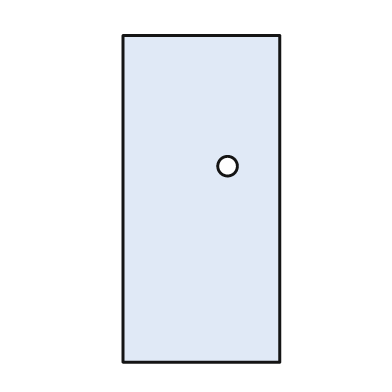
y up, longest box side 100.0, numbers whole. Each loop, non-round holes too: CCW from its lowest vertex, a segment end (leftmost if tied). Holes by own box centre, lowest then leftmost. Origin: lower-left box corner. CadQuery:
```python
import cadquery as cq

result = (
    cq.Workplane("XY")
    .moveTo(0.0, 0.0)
    .lineTo(48.0, 0.0)
    .lineTo(48.0, 100.0)
    .lineTo(0.0, 100.0)
    .close()
    .moveTo(32.0, 60.0)
    .circle(3.0)
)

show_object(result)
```